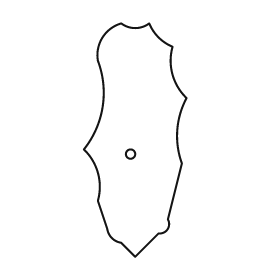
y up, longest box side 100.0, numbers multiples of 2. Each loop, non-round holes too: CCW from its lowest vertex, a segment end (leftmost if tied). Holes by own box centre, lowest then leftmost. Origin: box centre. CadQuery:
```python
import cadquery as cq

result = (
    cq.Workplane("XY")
    .moveTo(0.0, -50.0)
    .lineTo(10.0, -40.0)
    .threePointArc((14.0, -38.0), (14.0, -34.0))
    .lineTo(20.0, -10.0)
    .threePointArc((18.0, 4.0), (22.0, 18.0))
    .threePointArc((16.0, 28.0), (16.0, 40.0))
    .threePointArc((10.0, 44.0), (6.0, 50.0))
    .threePointArc((0.0, 48.0), (-6.0, 50.0))
    .threePointArc((-14.0, 44.0), (-16.0, 34.0))
    .threePointArc((-14.0, 14.0), (-22.0, -4.0))
    .threePointArc((-16.0, -14.0), (-16.0, -26.0))
    .lineTo(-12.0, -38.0)
    .threePointArc((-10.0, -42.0), (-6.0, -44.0))
    .close()
    .moveTo(-2.0, -6.0)
    .circle(2.0)
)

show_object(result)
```